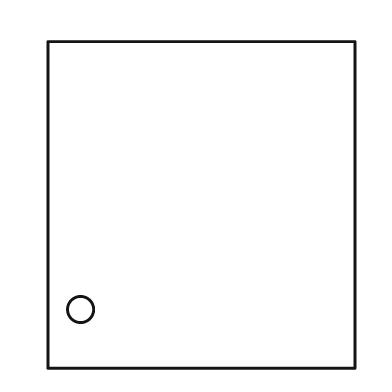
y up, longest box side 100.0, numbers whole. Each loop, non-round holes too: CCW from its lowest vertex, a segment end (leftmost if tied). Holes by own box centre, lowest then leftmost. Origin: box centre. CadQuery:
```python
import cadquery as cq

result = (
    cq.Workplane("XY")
    .moveTo(-47.0, -50.0)
    .lineTo(47.0, -50.0)
    .lineTo(47.0, 50.0)
    .lineTo(-47.0, 50.0)
    .close()
    .moveTo(-37.0, -32.0)
    .circle(4.0)
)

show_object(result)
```